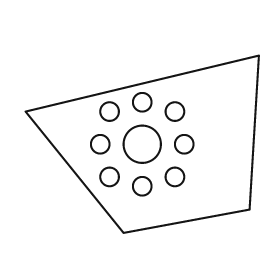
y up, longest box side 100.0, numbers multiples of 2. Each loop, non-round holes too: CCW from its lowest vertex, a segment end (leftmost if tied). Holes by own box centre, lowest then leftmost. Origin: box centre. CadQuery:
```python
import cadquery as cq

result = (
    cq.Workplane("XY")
    .moveTo(-8.0, -38.0)
    .lineTo(46.0, -28.0)
    .lineTo(50.0, 38.0)
    .lineTo(-50.0, 14.0)
    .close()
    .moveTo(0.0, -18.0)
    .circle(4.0)
    .moveTo(-14.0, -14.0)
    .circle(4.0)
    .moveTo(14.0, -14.0)
    .circle(4.0)
    .moveTo(-18.0, 0.0)
    .circle(4.0)
    .moveTo(0.0, 0.0)
    .circle(8.0)
    .moveTo(18.0, 0.0)
    .circle(4.0)
    .moveTo(-14.0, 14.0)
    .circle(4.0)
    .moveTo(14.0, 14.0)
    .circle(4.0)
    .moveTo(0.0, 18.0)
    .circle(4.0)
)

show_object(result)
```